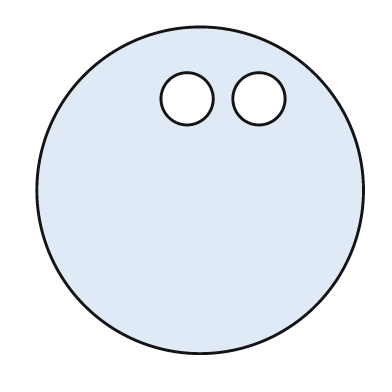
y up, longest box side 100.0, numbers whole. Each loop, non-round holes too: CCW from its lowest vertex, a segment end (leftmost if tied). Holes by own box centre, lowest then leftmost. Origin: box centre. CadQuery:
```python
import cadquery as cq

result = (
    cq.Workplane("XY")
    .moveTo(0.0, 0.0)
    .circle(50.0)
    .moveTo(-4.0, 28.0)
    .circle(8.0)
    .moveTo(18.0, 28.0)
    .circle(8.0)
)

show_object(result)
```